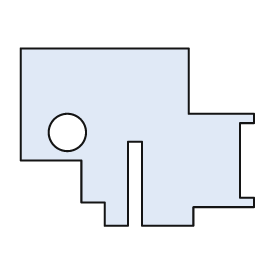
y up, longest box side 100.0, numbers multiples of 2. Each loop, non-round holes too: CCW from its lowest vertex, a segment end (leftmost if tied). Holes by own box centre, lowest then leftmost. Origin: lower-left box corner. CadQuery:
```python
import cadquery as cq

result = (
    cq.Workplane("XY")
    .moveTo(36.0, 0.0)
    .lineTo(46.0, 0.0)
    .lineTo(46.0, 36.0)
    .lineTo(52.0, 36.0)
    .lineTo(52.0, 0.0)
    .lineTo(74.0, 0.0)
    .lineTo(74.0, 8.0)
    .lineTo(100.0, 8.0)
    .lineTo(100.0, 12.0)
    .lineTo(94.0, 12.0)
    .lineTo(94.0, 44.0)
    .lineTo(100.0, 44.0)
    .lineTo(100.0, 48.0)
    .lineTo(72.0, 48.0)
    .lineTo(72.0, 76.0)
    .lineTo(0.0, 76.0)
    .lineTo(0.0, 28.0)
    .lineTo(26.0, 28.0)
    .lineTo(26.0, 10.0)
    .lineTo(36.0, 10.0)
    .close()
    .moveTo(20.0, 40.0)
    .circle(8.0)
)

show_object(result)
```